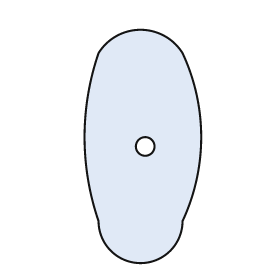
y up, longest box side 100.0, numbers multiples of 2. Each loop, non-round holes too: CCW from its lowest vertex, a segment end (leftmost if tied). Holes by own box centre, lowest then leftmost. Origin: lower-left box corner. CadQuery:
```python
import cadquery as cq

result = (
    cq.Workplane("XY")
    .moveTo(6.0, 18.0)
    .threePointArc((24.0, 0.0), (42.0, 18.0))
    .threePointArc((50.0, 54.0), (42.0, 90.0))
    .threePointArc((24.0, 100.0), (6.0, 90.0))
    .threePointArc((0.0, 54.0), (6.0, 18.0))
    .close()
    .moveTo(26.0, 50.0)
    .circle(4.0)
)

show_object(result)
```